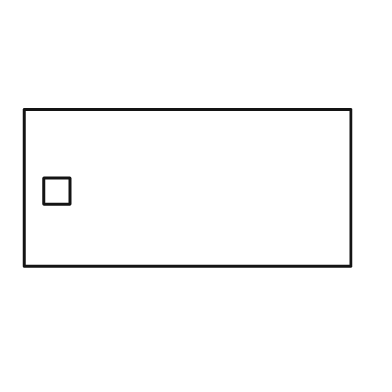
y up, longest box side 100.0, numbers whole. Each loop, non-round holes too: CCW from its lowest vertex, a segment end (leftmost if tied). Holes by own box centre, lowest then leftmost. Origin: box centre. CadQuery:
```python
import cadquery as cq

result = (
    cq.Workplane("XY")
    .moveTo(-50.0, -24.0)
    .lineTo(50.0, -24.0)
    .lineTo(50.0, 24.0)
    .lineTo(-50.0, 24.0)
    .close()
    .moveTo(-44.0, -5.0)
    .lineTo(-36.0, -5.0)
    .lineTo(-36.0, 3.0)
    .lineTo(-44.0, 3.0)
    .close()
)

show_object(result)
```